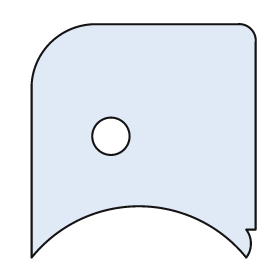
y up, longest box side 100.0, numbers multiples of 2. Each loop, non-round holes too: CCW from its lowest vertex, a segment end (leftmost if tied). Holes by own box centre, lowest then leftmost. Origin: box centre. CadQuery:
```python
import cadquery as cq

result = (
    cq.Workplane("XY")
    .moveTo(-48.0, -50.0)
    .threePointArc((-2.0, -28.0), (44.0, -50.0))
    .threePointArc((46.0, -44.0), (44.0, -38.0))
    .lineTo(48.0, -38.0)
    .lineTo(48.0, 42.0)
    .threePointArc((46.0, 48.0), (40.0, 50.0))
    .lineTo(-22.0, 50.0)
    .threePointArc((-40.0, 42.0), (-48.0, 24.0))
    .close()
    .moveTo(-14.0, 2.0)
    .circle(8.0)
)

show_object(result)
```